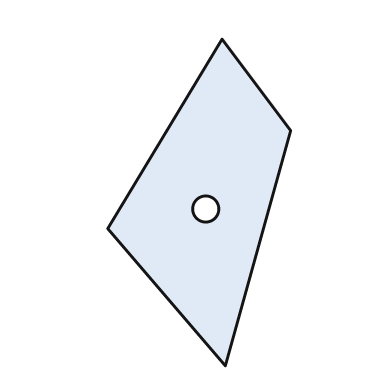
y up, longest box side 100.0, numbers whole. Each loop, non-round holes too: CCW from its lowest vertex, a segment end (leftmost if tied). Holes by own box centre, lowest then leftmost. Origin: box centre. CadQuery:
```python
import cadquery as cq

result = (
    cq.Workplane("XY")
    .moveTo(8.0, -50.0)
    .lineTo(28.0, 22.0)
    .lineTo(7.0, 50.0)
    .lineTo(-28.0, -8.0)
    .close()
    .moveTo(2.0, -2.0)
    .circle(4.0)
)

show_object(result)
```